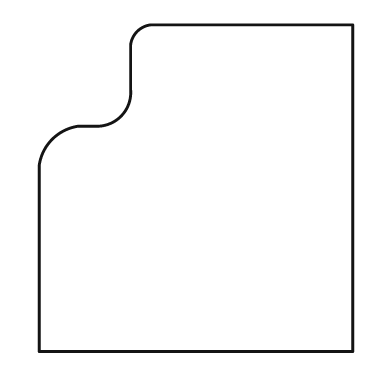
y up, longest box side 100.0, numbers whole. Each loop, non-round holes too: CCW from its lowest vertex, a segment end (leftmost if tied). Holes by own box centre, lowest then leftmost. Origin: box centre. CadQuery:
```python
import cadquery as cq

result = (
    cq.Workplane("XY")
    .moveTo(-48.0, -50.0)
    .lineTo(48.0, -50.0)
    .lineTo(48.0, 50.0)
    .lineTo(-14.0, 50.0)
    .threePointArc((-18.0, 48.0), (-20.0, 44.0))
    .lineTo(-20.0, 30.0)
    .threePointArc((-23.0, 22.0), (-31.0, 19.0))
    .lineTo(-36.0, 19.0)
    .threePointArc((-44.0, 15.0), (-48.0, 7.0))
    .close()
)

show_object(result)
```